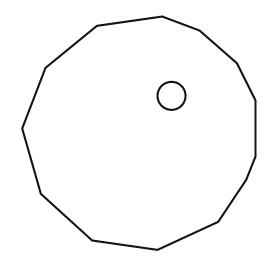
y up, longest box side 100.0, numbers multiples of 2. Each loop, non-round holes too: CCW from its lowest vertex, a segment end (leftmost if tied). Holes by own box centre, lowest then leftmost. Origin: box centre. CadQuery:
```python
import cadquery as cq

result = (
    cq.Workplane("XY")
    .moveTo(8.0, -50.0)
    .lineTo(34.0, -38.0)
    .lineTo(46.0, -20.0)
    .lineTo(50.0, -10.0)
    .lineTo(50.0, 14.0)
    .lineTo(42.0, 30.0)
    .lineTo(26.0, 44.0)
    .lineTo(10.0, 50.0)
    .lineTo(-18.0, 46.0)
    .lineTo(-40.0, 28.0)
    .lineTo(-50.0, 2.0)
    .lineTo(-42.0, -26.0)
    .lineTo(-20.0, -46.0)
    .close()
    .moveTo(14.0, 16.0)
    .circle(6.0)
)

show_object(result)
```